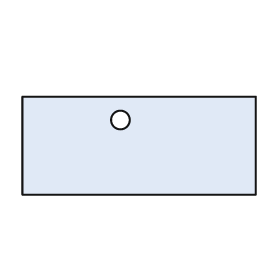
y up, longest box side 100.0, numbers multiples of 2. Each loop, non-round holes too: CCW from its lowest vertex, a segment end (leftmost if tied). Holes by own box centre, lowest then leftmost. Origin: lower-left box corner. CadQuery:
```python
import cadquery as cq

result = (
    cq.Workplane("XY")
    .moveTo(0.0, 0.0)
    .lineTo(100.0, 0.0)
    .lineTo(100.0, 42.0)
    .lineTo(0.0, 42.0)
    .close()
    .moveTo(42.0, 32.0)
    .circle(4.0)
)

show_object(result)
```